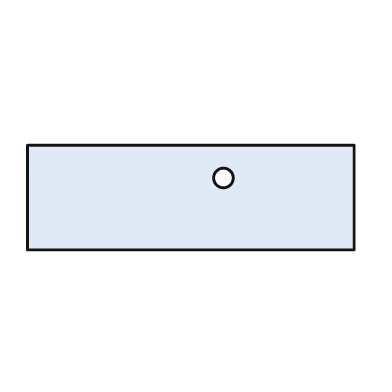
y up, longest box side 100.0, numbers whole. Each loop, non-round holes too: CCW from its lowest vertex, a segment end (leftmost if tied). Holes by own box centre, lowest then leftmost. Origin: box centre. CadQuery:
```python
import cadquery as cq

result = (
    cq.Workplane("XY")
    .moveTo(-50.0, -16.0)
    .lineTo(50.0, -16.0)
    .lineTo(50.0, 16.0)
    .lineTo(-50.0, 16.0)
    .close()
    .moveTo(10.0, 6.0)
    .circle(3.0)
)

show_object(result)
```